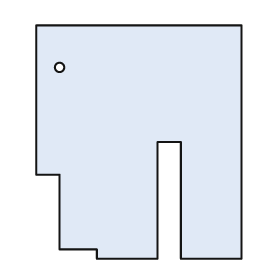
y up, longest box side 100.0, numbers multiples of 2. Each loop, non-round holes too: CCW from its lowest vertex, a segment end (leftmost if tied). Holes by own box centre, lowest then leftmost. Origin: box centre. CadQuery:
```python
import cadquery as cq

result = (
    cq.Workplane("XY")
    .moveTo(-18.0, -50.0)
    .lineTo(8.0, -50.0)
    .lineTo(8.0, 0.0)
    .lineTo(18.0, 0.0)
    .lineTo(18.0, -50.0)
    .lineTo(44.0, -50.0)
    .lineTo(44.0, 50.0)
    .lineTo(-44.0, 50.0)
    .lineTo(-44.0, -14.0)
    .lineTo(-34.0, -14.0)
    .lineTo(-34.0, -46.0)
    .lineTo(-18.0, -46.0)
    .close()
    .moveTo(-34.0, 32.0)
    .circle(2.0)
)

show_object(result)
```